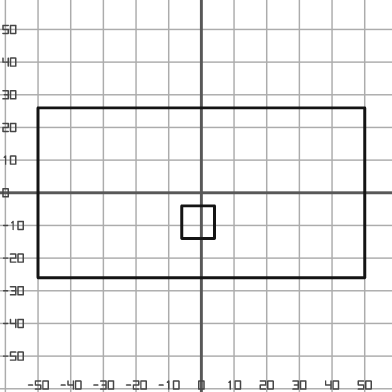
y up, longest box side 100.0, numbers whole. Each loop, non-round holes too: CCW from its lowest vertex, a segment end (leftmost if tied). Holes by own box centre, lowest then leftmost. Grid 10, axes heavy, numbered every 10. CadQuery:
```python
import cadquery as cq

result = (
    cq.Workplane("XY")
    .moveTo(-50.0, -26.0)
    .lineTo(50.0, -26.0)
    .lineTo(50.0, 26.0)
    .lineTo(-50.0, 26.0)
    .close()
    .moveTo(-6.0, -14.0)
    .lineTo(4.0, -14.0)
    .lineTo(4.0, -4.0)
    .lineTo(-6.0, -4.0)
    .close()
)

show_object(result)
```